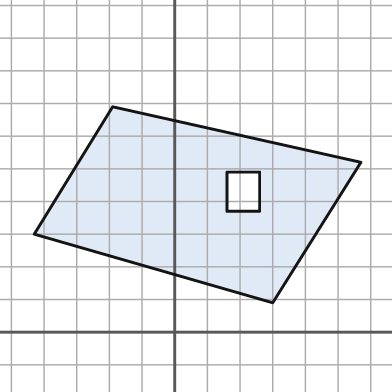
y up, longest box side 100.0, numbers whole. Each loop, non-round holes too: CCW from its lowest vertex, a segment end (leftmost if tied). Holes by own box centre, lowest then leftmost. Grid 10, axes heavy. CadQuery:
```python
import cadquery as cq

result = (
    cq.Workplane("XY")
    .moveTo(30.0, 9.0)
    .lineTo(57.0, 52.0)
    .lineTo(-19.0, 69.0)
    .lineTo(-43.0, 30.0)
    .close()
    .moveTo(16.0, 37.0)
    .lineTo(26.0, 37.0)
    .lineTo(26.0, 49.0)
    .lineTo(16.0, 49.0)
    .close()
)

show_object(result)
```